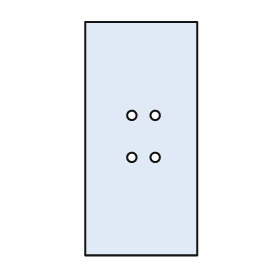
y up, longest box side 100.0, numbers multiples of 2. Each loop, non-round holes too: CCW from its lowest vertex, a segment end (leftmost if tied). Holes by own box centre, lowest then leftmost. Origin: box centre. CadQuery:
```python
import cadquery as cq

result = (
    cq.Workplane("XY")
    .moveTo(-24.0, -50.0)
    .lineTo(24.0, -50.0)
    .lineTo(24.0, 50.0)
    .lineTo(-24.0, 50.0)
    .close()
    .moveTo(-4.0, -8.0)
    .circle(2.0)
    .moveTo(6.0, -8.0)
    .circle(2.0)
    .moveTo(-4.0, 10.0)
    .circle(2.0)
    .moveTo(6.0, 10.0)
    .circle(2.0)
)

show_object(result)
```